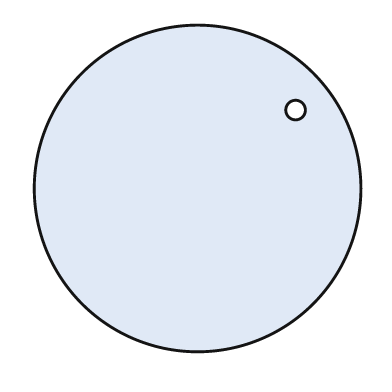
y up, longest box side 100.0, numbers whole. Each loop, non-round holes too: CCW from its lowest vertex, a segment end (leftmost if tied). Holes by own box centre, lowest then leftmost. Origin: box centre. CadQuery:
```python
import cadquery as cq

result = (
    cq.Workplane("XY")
    .moveTo(0.0, 0.0)
    .circle(50.0)
    .moveTo(30.0, 24.0)
    .circle(3.0)
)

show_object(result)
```